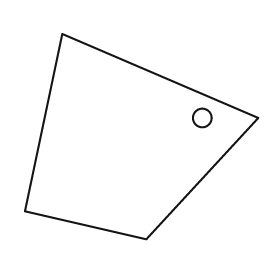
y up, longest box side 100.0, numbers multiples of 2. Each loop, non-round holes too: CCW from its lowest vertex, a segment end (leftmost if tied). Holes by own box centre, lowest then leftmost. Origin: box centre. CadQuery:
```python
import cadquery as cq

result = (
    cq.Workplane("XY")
    .moveTo(2.0, -44.0)
    .lineTo(50.0, 8.0)
    .lineTo(-34.0, 44.0)
    .lineTo(-50.0, -32.0)
    .close()
    .moveTo(26.0, 8.0)
    .circle(4.0)
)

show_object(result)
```